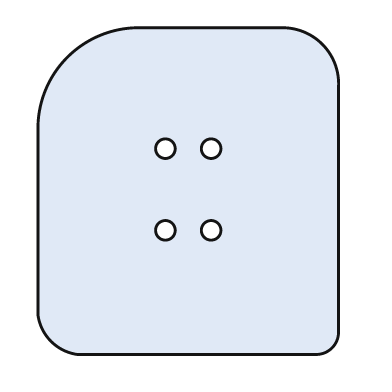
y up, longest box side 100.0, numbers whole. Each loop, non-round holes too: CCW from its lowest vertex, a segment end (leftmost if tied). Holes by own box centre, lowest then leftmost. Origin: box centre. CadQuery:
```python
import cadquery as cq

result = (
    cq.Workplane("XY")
    .moveTo(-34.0, -50.0)
    .lineTo(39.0, -50.0)
    .threePointArc((44.0, -48.0), (46.0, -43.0))
    .lineTo(46.0, 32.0)
    .threePointArc((41.0, 45.0), (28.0, 50.0))
    .lineTo(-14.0, 50.0)
    .threePointArc((-37.0, 41.0), (-46.0, 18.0))
    .lineTo(-46.0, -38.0)
    .threePointArc((-42.0, -46.0), (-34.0, -50.0))
    .close()
    .moveTo(-7.0, -12.0)
    .circle(3.0)
    .moveTo(7.0, -12.0)
    .circle(3.0)
    .moveTo(-7.0, 13.0)
    .circle(3.0)
    .moveTo(7.0, 13.0)
    .circle(3.0)
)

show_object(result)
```